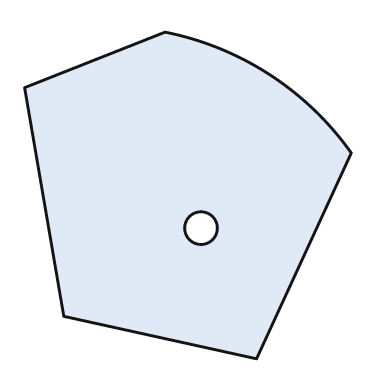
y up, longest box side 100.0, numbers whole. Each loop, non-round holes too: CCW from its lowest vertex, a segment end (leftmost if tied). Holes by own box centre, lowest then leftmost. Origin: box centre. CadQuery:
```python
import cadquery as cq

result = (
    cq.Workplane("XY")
    .moveTo(21.0, -50.0)
    .lineTo(50.0, 13.0)
    .threePointArc((25.0, 37.0), (-7.0, 50.0))
    .lineTo(-50.0, 33.0)
    .lineTo(-38.0, -37.0)
    .close()
    .moveTo(4.0, -10.0)
    .circle(5.0)
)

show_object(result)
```